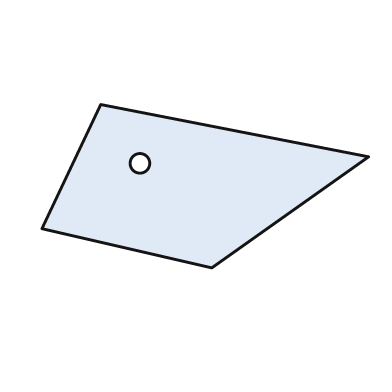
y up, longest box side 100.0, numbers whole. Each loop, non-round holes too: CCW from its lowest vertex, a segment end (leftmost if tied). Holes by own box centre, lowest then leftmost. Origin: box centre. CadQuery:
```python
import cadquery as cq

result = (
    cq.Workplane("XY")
    .moveTo(2.0, -25.0)
    .lineTo(50.0, 9.0)
    .lineTo(-32.0, 25.0)
    .lineTo(-50.0, -13.0)
    .close()
    .moveTo(-20.0, 7.0)
    .circle(3.0)
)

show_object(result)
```